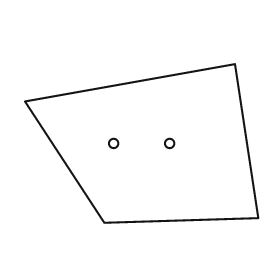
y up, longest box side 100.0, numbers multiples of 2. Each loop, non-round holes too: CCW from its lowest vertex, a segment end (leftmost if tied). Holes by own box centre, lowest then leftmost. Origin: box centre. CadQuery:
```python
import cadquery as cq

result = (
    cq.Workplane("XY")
    .moveTo(-16.0, -34.0)
    .lineTo(50.0, -32.0)
    .lineTo(40.0, 34.0)
    .lineTo(-50.0, 18.0)
    .close()
    .moveTo(-12.0, 0.0)
    .circle(2.0)
    .moveTo(12.0, 0.0)
    .circle(2.0)
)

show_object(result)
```